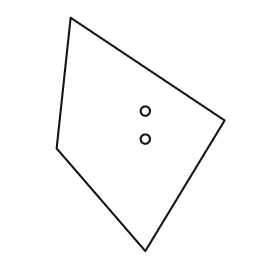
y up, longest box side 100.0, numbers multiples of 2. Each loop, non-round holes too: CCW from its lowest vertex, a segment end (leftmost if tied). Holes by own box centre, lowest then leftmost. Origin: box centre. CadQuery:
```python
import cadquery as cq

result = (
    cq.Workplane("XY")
    .moveTo(2.0, -50.0)
    .lineTo(36.0, 6.0)
    .lineTo(-30.0, 50.0)
    .lineTo(-36.0, -6.0)
    .close()
    .moveTo(2.0, -2.0)
    .circle(2.0)
    .moveTo(2.0, 10.0)
    .circle(2.0)
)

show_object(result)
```